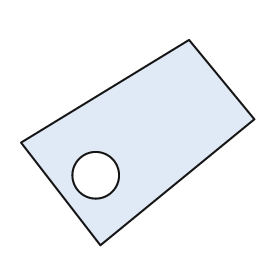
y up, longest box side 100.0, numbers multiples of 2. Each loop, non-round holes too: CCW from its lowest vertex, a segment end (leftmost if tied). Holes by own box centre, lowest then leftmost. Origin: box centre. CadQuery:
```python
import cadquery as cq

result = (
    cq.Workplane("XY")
    .moveTo(-16.0, -44.0)
    .lineTo(50.0, 10.0)
    .lineTo(22.0, 44.0)
    .lineTo(-50.0, 0.0)
    .close()
    .moveTo(-18.0, -14.0)
    .circle(10.0)
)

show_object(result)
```